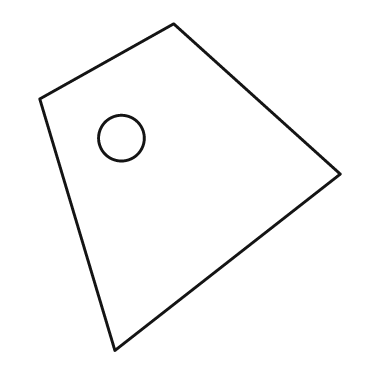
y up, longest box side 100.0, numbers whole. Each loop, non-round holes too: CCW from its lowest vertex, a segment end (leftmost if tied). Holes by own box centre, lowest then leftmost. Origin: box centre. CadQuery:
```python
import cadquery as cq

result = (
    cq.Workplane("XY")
    .moveTo(-23.0, -50.0)
    .lineTo(46.0, 4.0)
    .lineTo(-5.0, 50.0)
    .lineTo(-46.0, 27.0)
    .close()
    .moveTo(-21.0, 15.0)
    .circle(7.0)
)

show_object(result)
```